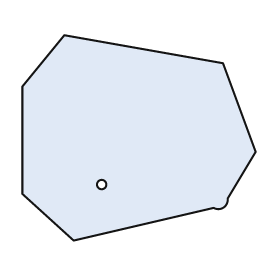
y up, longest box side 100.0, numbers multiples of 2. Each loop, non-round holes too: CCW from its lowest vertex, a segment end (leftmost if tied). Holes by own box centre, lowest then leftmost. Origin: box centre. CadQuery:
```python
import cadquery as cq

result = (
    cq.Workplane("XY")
    .moveTo(-28.0, -44.0)
    .lineTo(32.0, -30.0)
    .threePointArc((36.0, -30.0), (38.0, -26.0))
    .lineTo(50.0, -6.0)
    .lineTo(36.0, 32.0)
    .lineTo(-32.0, 44.0)
    .lineTo(-50.0, 22.0)
    .lineTo(-50.0, -24.0)
    .close()
    .moveTo(-16.0, -20.0)
    .circle(2.0)
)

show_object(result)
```